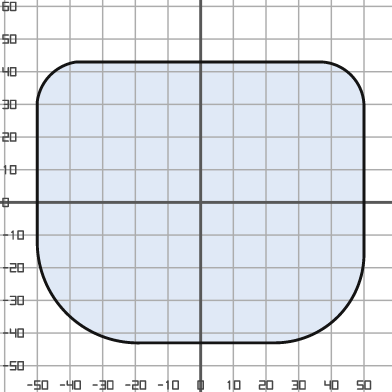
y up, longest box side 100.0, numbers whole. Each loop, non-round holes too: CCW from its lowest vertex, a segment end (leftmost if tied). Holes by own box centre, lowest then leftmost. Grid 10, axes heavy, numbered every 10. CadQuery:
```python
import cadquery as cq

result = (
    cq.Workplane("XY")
    .moveTo(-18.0, -43.0)
    .lineTo(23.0, -43.0)
    .threePointArc((42.0, -35.0), (50.0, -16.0))
    .lineTo(50.0, 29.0)
    .threePointArc((46.0, 39.0), (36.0, 43.0))
    .lineTo(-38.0, 43.0)
    .threePointArc((-46.0, 39.0), (-50.0, 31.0))
    .lineTo(-50.0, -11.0)
    .threePointArc((-41.0, -34.0), (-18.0, -43.0))
    .close()
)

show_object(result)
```